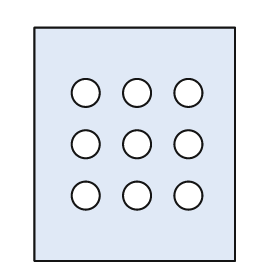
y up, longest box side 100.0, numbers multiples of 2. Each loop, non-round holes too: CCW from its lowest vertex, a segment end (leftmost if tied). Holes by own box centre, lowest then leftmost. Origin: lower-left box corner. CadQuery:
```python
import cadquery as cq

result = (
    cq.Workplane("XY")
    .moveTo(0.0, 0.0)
    .lineTo(86.0, 0.0)
    .lineTo(86.0, 100.0)
    .lineTo(0.0, 100.0)
    .close()
    .moveTo(22.0, 28.0)
    .circle(6.0)
    .moveTo(44.0, 28.0)
    .circle(6.0)
    .moveTo(66.0, 28.0)
    .circle(6.0)
    .moveTo(22.0, 50.0)
    .circle(6.0)
    .moveTo(44.0, 50.0)
    .circle(6.0)
    .moveTo(66.0, 50.0)
    .circle(6.0)
    .moveTo(22.0, 72.0)
    .circle(6.0)
    .moveTo(44.0, 72.0)
    .circle(6.0)
    .moveTo(66.0, 72.0)
    .circle(6.0)
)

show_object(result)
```